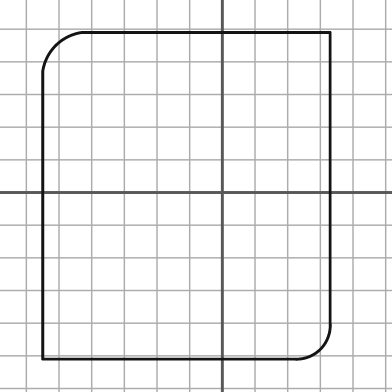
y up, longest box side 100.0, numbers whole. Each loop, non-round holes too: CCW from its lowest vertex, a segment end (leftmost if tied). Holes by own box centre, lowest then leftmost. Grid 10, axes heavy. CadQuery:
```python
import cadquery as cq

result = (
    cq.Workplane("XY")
    .moveTo(-55.0, -51.0)
    .lineTo(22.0, -51.0)
    .threePointArc((30.0, -48.0), (33.0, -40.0))
    .lineTo(33.0, 49.0)
    .lineTo(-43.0, 49.0)
    .threePointArc((-51.0, 45.0), (-55.0, 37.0))
    .close()
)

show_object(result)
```